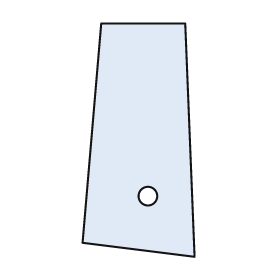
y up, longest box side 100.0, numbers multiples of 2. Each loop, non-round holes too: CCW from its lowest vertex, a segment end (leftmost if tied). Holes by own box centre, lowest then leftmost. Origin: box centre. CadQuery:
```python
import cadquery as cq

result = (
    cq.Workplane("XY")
    .moveTo(24.0, -50.0)
    .lineTo(20.0, 50.0)
    .lineTo(-16.0, 50.0)
    .lineTo(-24.0, -44.0)
    .close()
    .moveTo(4.0, -24.0)
    .circle(4.0)
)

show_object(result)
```